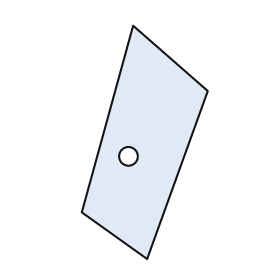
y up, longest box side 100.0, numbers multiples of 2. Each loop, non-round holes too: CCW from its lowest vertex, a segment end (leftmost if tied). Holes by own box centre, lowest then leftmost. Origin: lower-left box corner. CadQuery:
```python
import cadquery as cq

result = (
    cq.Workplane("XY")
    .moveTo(28.0, 0.0)
    .lineTo(54.0, 72.0)
    .lineTo(22.0, 100.0)
    .lineTo(0.0, 20.0)
    .close()
    .moveTo(20.0, 44.0)
    .circle(4.0)
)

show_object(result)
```